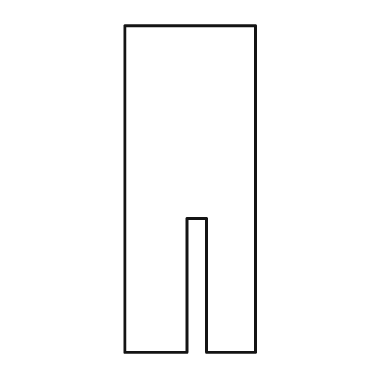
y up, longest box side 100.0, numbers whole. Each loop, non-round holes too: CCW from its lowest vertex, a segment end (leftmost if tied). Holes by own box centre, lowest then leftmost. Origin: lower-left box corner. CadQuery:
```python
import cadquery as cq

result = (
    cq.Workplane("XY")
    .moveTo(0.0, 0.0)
    .lineTo(19.0, 0.0)
    .lineTo(19.0, 41.0)
    .lineTo(25.0, 41.0)
    .lineTo(25.0, 0.0)
    .lineTo(40.0, 0.0)
    .lineTo(40.0, 100.0)
    .lineTo(0.0, 100.0)
    .close()
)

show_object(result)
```